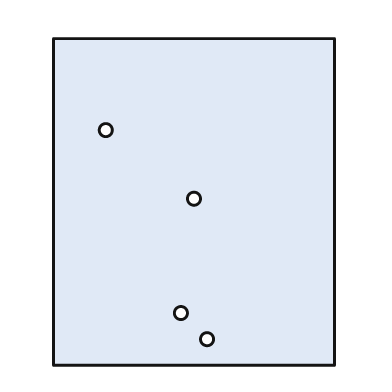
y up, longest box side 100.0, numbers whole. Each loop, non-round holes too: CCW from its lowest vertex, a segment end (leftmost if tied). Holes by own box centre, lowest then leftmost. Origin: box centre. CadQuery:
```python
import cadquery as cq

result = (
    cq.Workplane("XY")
    .moveTo(-43.0, -50.0)
    .lineTo(43.0, -50.0)
    .lineTo(43.0, 50.0)
    .lineTo(-43.0, 50.0)
    .close()
    .moveTo(4.0, -42.0)
    .circle(2.0)
    .moveTo(-4.0, -34.0)
    .circle(2.0)
    .moveTo(0.0, 1.0)
    .circle(2.0)
    .moveTo(-27.0, 22.0)
    .circle(2.0)
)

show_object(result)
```